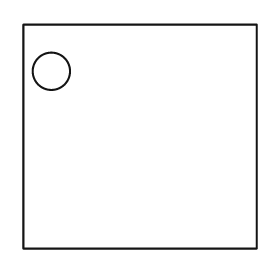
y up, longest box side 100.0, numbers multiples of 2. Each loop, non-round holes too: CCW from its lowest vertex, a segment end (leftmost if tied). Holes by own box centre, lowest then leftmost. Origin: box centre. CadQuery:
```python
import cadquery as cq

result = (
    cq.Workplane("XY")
    .moveTo(-50.0, -48.0)
    .lineTo(50.0, -48.0)
    .lineTo(50.0, 48.0)
    .lineTo(-50.0, 48.0)
    .close()
    .moveTo(-38.0, 28.0)
    .circle(8.0)
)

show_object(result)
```